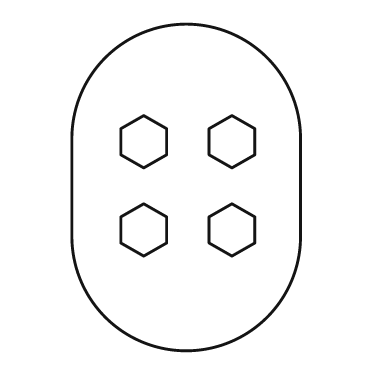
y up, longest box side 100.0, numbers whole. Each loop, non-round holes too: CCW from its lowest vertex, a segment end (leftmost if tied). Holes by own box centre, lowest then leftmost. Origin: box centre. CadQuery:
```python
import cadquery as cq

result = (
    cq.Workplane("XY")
    .moveTo(-35.0, -15.0)
    .threePointArc((0.0, -50.0), (35.0, -15.0))
    .lineTo(35.0, 15.0)
    .threePointArc((0.0, 50.0), (-35.0, 15.0))
    .close()
    .moveTo(-13.0, -21.0)
    .lineTo(-6.0, -17.0)
    .lineTo(-6.0, -9.0)
    .lineTo(-13.0, -5.0)
    .lineTo(-20.0, -9.0)
    .lineTo(-20.0, -17.0)
    .close()
    .moveTo(14.0, -21.0)
    .lineTo(21.0, -17.0)
    .lineTo(21.0, -9.0)
    .lineTo(14.0, -5.0)
    .lineTo(7.0, -9.0)
    .lineTo(7.0, -17.0)
    .close()
    .moveTo(-13.0, 6.0)
    .lineTo(-6.0, 10.0)
    .lineTo(-6.0, 18.0)
    .lineTo(-13.0, 22.0)
    .lineTo(-20.0, 18.0)
    .lineTo(-20.0, 10.0)
    .close()
    .moveTo(14.0, 6.0)
    .lineTo(21.0, 10.0)
    .lineTo(21.0, 18.0)
    .lineTo(14.0, 22.0)
    .lineTo(7.0, 18.0)
    .lineTo(7.0, 10.0)
    .close()
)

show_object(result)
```